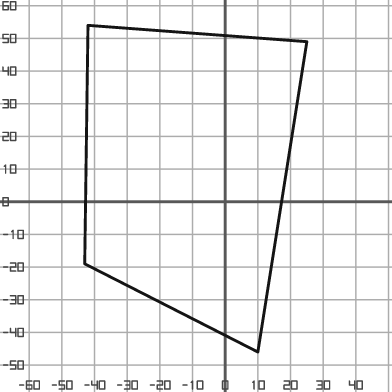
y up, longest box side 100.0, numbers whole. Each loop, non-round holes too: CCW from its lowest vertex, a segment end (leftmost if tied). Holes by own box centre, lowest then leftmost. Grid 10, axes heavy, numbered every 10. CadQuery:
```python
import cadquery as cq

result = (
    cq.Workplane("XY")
    .moveTo(10.0, -46.0)
    .lineTo(25.0, 49.0)
    .lineTo(-42.0, 54.0)
    .lineTo(-43.0, -19.0)
    .close()
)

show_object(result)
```